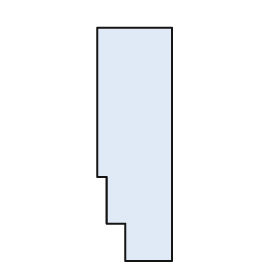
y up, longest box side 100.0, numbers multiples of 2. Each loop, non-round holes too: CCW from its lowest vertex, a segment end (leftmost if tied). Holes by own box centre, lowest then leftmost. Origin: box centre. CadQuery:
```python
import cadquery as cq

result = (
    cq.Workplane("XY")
    .moveTo(-4.0, -50.0)
    .lineTo(16.0, -50.0)
    .lineTo(16.0, 50.0)
    .lineTo(-16.0, 50.0)
    .lineTo(-16.0, -14.0)
    .lineTo(-12.0, -14.0)
    .lineTo(-12.0, -34.0)
    .lineTo(-4.0, -34.0)
    .close()
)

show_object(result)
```